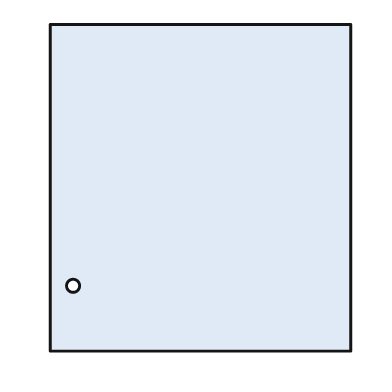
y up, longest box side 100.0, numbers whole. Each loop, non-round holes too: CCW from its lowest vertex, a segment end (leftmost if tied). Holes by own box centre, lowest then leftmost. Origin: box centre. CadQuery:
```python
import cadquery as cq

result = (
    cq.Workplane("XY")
    .moveTo(-46.0, -50.0)
    .lineTo(46.0, -50.0)
    .lineTo(46.0, 50.0)
    .lineTo(-46.0, 50.0)
    .close()
    .moveTo(-39.0, -30.0)
    .circle(2.0)
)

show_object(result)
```